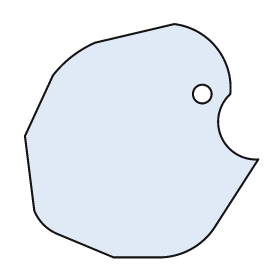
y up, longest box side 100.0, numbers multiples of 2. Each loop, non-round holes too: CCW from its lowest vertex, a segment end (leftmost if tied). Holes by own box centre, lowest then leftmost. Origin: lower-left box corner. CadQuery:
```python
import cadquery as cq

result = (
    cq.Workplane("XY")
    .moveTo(38.0, 0.0)
    .lineTo(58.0, 0.0)
    .threePointArc((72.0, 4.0), (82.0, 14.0))
    .lineTo(100.0, 42.0)
    .threePointArc((84.0, 52.0), (88.0, 70.0))
    .threePointArc((82.0, 90.0), (64.0, 100.0))
    .lineTo(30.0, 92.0)
    .threePointArc((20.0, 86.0), (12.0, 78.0))
    .lineTo(0.0, 52.0)
    .lineTo(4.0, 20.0)
    .threePointArc((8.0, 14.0), (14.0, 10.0))
    .close()
    .moveTo(76.0, 70.0)
    .circle(4.0)
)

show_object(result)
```